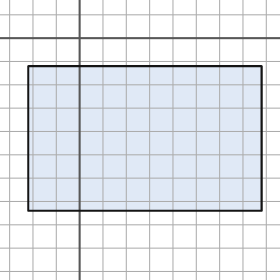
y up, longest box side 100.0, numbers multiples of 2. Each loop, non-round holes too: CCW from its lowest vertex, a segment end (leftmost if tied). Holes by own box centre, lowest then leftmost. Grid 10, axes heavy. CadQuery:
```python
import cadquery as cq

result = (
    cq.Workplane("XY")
    .moveTo(-22.0, -74.0)
    .lineTo(78.0, -74.0)
    .lineTo(78.0, -12.0)
    .lineTo(-22.0, -12.0)
    .close()
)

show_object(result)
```